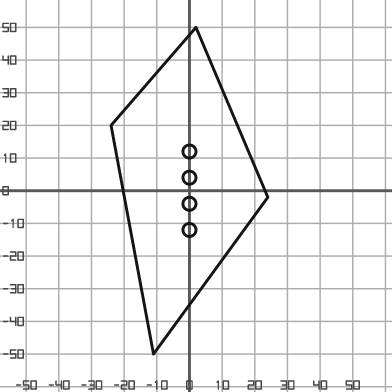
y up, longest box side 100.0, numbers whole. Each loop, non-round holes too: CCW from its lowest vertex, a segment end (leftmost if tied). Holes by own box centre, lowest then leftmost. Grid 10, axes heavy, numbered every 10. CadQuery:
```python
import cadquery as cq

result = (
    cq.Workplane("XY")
    .moveTo(-11.0, -50.0)
    .lineTo(24.0, -2.0)
    .lineTo(2.0, 50.0)
    .lineTo(-24.0, 20.0)
    .close()
    .moveTo(0.0, -12.0)
    .circle(2.0)
    .moveTo(0.0, -4.0)
    .circle(2.0)
    .moveTo(0.0, 4.0)
    .circle(2.0)
    .moveTo(0.0, 12.0)
    .circle(2.0)
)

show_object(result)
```